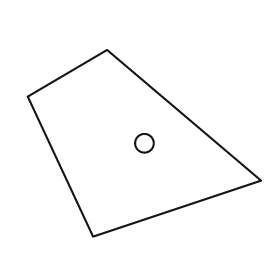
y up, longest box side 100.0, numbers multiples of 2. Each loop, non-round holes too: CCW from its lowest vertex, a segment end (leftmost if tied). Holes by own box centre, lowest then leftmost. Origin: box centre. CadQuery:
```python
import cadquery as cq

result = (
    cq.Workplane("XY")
    .moveTo(-22.0, -40.0)
    .lineTo(50.0, -16.0)
    .lineTo(-16.0, 40.0)
    .lineTo(-50.0, 20.0)
    .close()
    .moveTo(0.0, 0.0)
    .circle(4.0)
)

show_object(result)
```